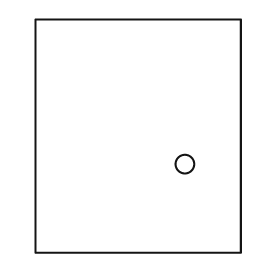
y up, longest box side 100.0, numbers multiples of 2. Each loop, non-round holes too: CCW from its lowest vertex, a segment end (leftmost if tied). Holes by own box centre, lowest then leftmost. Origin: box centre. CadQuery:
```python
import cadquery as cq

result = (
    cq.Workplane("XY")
    .moveTo(-44.0, -50.0)
    .lineTo(44.0, -50.0)
    .lineTo(44.0, 50.0)
    .lineTo(-44.0, 50.0)
    .close()
    .moveTo(20.0, -12.0)
    .circle(4.0)
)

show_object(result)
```